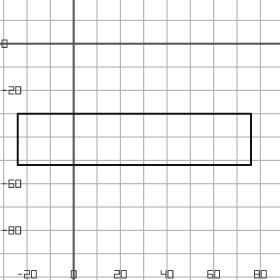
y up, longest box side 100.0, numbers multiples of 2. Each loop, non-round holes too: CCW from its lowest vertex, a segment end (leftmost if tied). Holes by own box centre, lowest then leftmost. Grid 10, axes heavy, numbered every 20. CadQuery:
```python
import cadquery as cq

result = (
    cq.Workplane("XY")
    .moveTo(-24.0, -52.0)
    .lineTo(76.0, -52.0)
    .lineTo(76.0, -30.0)
    .lineTo(-24.0, -30.0)
    .close()
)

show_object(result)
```